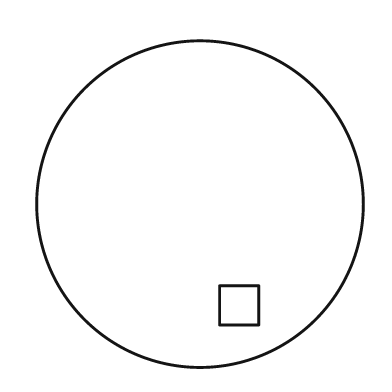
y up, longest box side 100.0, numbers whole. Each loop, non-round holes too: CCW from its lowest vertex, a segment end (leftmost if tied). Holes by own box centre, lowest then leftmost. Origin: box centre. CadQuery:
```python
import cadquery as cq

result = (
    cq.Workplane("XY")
    .moveTo(0.0, 0.0)
    .circle(50.0)
    .moveTo(6.0, -37.0)
    .lineTo(18.0, -37.0)
    .lineTo(18.0, -25.0)
    .lineTo(6.0, -25.0)
    .close()
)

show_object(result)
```